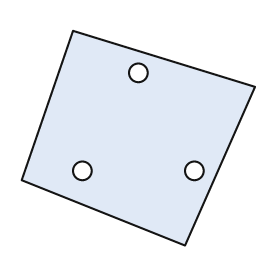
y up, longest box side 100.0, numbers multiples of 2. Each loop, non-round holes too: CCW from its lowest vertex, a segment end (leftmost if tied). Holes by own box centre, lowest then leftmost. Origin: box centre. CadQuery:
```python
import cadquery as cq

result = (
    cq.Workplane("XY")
    .moveTo(20.0, -46.0)
    .lineTo(50.0, 22.0)
    .lineTo(-28.0, 46.0)
    .lineTo(-50.0, -18.0)
    .close()
    .moveTo(-24.0, -14.0)
    .circle(4.0)
    .moveTo(24.0, -14.0)
    .circle(4.0)
    .moveTo(0.0, 28.0)
    .circle(4.0)
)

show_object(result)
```